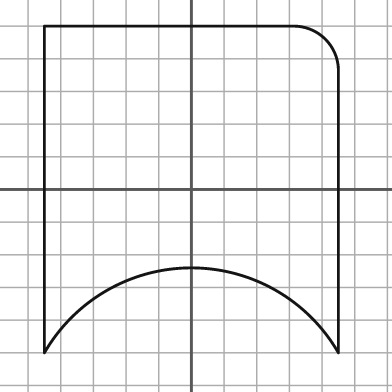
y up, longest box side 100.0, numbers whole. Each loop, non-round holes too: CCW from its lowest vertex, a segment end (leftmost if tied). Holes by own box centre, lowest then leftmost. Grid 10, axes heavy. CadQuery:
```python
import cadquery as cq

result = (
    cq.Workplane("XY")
    .moveTo(-45.0, -50.0)
    .threePointArc((0.0, -24.0), (45.0, -50.0))
    .lineTo(45.0, 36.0)
    .threePointArc((41.0, 46.0), (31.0, 50.0))
    .lineTo(-45.0, 50.0)
    .close()
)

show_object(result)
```